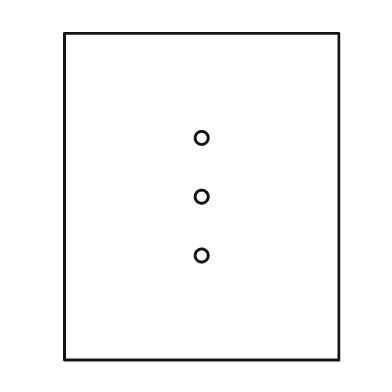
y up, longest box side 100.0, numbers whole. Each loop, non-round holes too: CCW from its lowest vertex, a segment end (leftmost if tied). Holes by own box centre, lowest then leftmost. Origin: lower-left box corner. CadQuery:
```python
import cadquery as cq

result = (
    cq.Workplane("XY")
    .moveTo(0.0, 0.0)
    .lineTo(84.0, 0.0)
    .lineTo(84.0, 100.0)
    .lineTo(0.0, 100.0)
    .close()
    .moveTo(42.0, 32.0)
    .circle(2.0)
    .moveTo(42.0, 50.0)
    .circle(2.0)
    .moveTo(42.0, 68.0)
    .circle(2.0)
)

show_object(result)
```